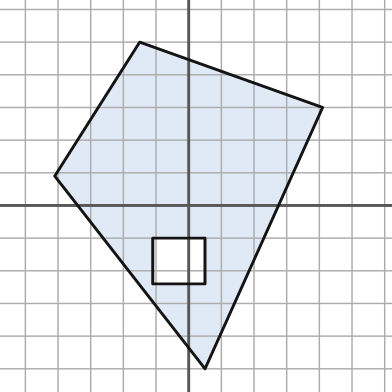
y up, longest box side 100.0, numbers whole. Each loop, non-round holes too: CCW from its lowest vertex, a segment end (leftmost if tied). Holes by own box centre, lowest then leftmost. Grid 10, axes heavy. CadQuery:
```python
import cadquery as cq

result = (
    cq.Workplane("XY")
    .moveTo(5.0, -50.0)
    .lineTo(41.0, 30.0)
    .lineTo(-15.0, 50.0)
    .lineTo(-41.0, 9.0)
    .close()
    .moveTo(-11.0, -24.0)
    .lineTo(5.0, -24.0)
    .lineTo(5.0, -10.0)
    .lineTo(-11.0, -10.0)
    .close()
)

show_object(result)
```